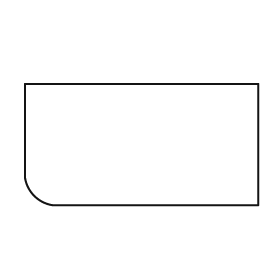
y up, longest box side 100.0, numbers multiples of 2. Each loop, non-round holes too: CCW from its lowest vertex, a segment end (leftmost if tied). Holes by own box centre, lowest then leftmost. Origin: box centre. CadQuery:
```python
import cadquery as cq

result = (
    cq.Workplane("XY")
    .moveTo(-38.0, -26.0)
    .lineTo(50.0, -26.0)
    .lineTo(50.0, 26.0)
    .lineTo(-50.0, 26.0)
    .lineTo(-50.0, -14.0)
    .threePointArc((-46.0, -22.0), (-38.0, -26.0))
    .close()
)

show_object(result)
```